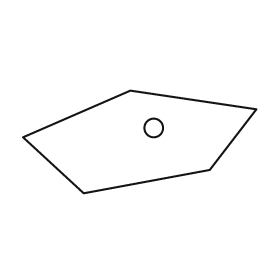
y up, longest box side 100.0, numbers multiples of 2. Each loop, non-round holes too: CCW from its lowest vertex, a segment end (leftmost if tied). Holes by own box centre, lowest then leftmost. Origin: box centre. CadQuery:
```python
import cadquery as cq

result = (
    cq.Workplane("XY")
    .moveTo(-24.0, -22.0)
    .lineTo(30.0, -12.0)
    .lineTo(50.0, 14.0)
    .lineTo(-4.0, 22.0)
    .lineTo(-50.0, 2.0)
    .close()
    .moveTo(6.0, 6.0)
    .circle(4.0)
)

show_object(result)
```